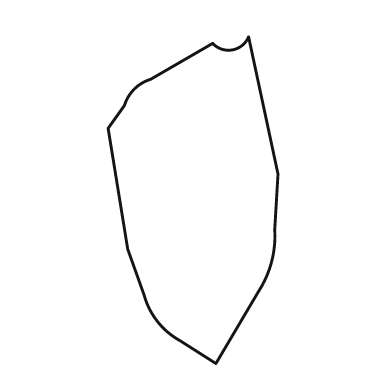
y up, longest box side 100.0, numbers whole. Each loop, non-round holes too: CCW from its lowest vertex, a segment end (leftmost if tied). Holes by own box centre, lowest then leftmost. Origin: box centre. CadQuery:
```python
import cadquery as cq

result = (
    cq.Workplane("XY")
    .moveTo(7.0, -50.0)
    .lineTo(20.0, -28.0)
    .threePointArc((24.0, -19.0), (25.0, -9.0))
    .lineTo(26.0, 8.0)
    .lineTo(17.0, 50.0)
    .threePointArc((12.0, 46.0), (6.0, 48.0))
    .lineTo(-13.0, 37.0)
    .threePointArc((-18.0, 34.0), (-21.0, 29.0))
    .lineTo(-26.0, 22.0)
    .lineTo(-20.0, -15.0)
    .lineTo(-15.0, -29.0)
    .threePointArc((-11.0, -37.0), (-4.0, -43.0))
    .close()
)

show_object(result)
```